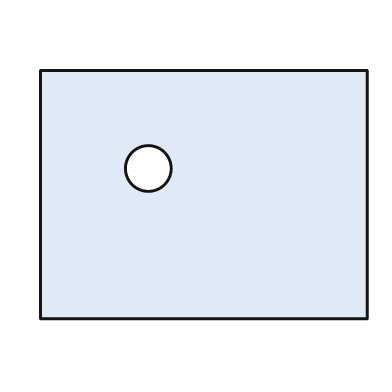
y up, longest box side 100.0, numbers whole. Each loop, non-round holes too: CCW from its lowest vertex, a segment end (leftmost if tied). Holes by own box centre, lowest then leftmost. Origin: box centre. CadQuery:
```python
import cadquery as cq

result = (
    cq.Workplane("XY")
    .moveTo(-50.0, -38.0)
    .lineTo(50.0, -38.0)
    .lineTo(50.0, 38.0)
    .lineTo(-50.0, 38.0)
    .close()
    .moveTo(-17.0, 8.0)
    .circle(7.0)
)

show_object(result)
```